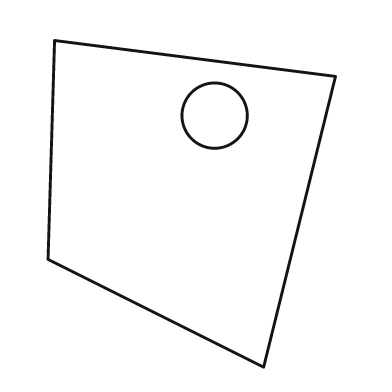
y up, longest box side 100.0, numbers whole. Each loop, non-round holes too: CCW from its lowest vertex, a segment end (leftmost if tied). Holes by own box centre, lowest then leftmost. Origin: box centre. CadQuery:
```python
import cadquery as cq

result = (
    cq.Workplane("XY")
    .moveTo(22.0, -50.0)
    .lineTo(44.0, 39.0)
    .lineTo(-42.0, 50.0)
    .lineTo(-44.0, -17.0)
    .close()
    .moveTo(7.0, 27.0)
    .circle(10.0)
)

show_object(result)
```